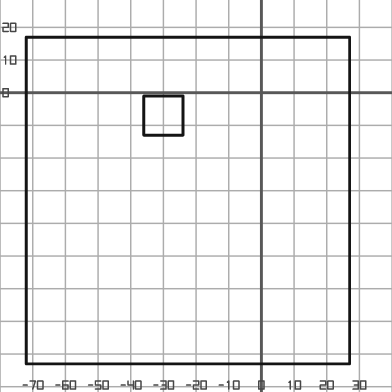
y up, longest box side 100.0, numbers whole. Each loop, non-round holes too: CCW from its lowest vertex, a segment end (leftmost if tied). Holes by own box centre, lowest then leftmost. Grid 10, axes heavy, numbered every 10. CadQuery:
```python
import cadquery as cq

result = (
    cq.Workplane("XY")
    .moveTo(-72.0, -83.0)
    .lineTo(27.0, -83.0)
    .lineTo(27.0, 17.0)
    .lineTo(-72.0, 17.0)
    .close()
    .moveTo(-36.0, -13.0)
    .lineTo(-24.0, -13.0)
    .lineTo(-24.0, -1.0)
    .lineTo(-36.0, -1.0)
    .close()
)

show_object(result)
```